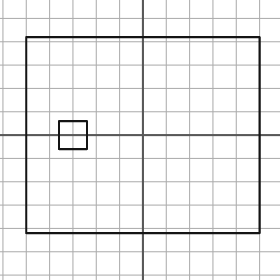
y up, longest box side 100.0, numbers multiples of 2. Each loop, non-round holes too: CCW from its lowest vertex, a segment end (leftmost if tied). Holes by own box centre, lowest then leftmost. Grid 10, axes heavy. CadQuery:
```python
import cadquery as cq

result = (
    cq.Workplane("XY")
    .moveTo(-50.0, -42.0)
    .lineTo(50.0, -42.0)
    .lineTo(50.0, 42.0)
    .lineTo(-50.0, 42.0)
    .close()
    .moveTo(-36.0, -6.0)
    .lineTo(-24.0, -6.0)
    .lineTo(-24.0, 6.0)
    .lineTo(-36.0, 6.0)
    .close()
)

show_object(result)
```